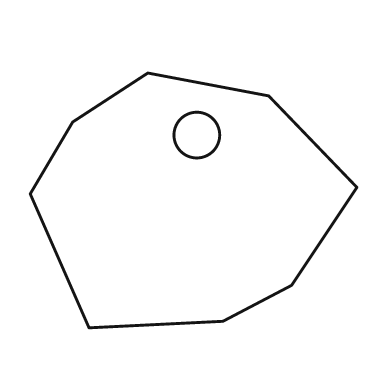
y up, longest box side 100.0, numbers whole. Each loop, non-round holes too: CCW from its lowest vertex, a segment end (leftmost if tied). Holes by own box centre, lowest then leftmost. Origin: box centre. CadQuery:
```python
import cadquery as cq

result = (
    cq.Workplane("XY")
    .moveTo(-32.0, -39.0)
    .lineTo(9.0, -37.0)
    .lineTo(30.0, -26.0)
    .lineTo(50.0, 4.0)
    .lineTo(23.0, 32.0)
    .lineTo(-14.0, 39.0)
    .lineTo(-37.0, 24.0)
    .lineTo(-50.0, 2.0)
    .close()
    .moveTo(1.0, 20.0)
    .circle(7.0)
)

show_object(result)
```